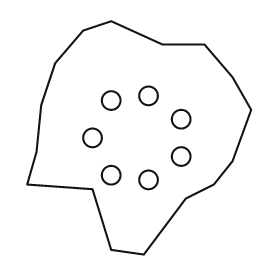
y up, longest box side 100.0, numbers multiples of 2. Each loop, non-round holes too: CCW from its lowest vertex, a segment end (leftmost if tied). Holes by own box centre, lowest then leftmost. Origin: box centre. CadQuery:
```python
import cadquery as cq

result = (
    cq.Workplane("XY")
    .moveTo(2.0, -50.0)
    .lineTo(20.0, -26.0)
    .lineTo(32.0, -20.0)
    .lineTo(40.0, -10.0)
    .lineTo(48.0, 12.0)
    .lineTo(40.0, 26.0)
    .lineTo(28.0, 40.0)
    .lineTo(10.0, 40.0)
    .lineTo(-12.0, 50.0)
    .lineTo(-24.0, 46.0)
    .lineTo(-36.0, 32.0)
    .lineTo(-42.0, 14.0)
    .lineTo(-44.0, -6.0)
    .lineTo(-48.0, -20.0)
    .lineTo(-20.0, -22.0)
    .lineTo(-12.0, -48.0)
    .close()
    .moveTo(4.0, -18.0)
    .circle(4.0)
    .moveTo(-12.0, -16.0)
    .circle(4.0)
    .moveTo(18.0, -8.0)
    .circle(4.0)
    .moveTo(-20.0, 0.0)
    .circle(4.0)
    .moveTo(18.0, 8.0)
    .circle(4.0)
    .moveTo(-12.0, 16.0)
    .circle(4.0)
    .moveTo(4.0, 18.0)
    .circle(4.0)
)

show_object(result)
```